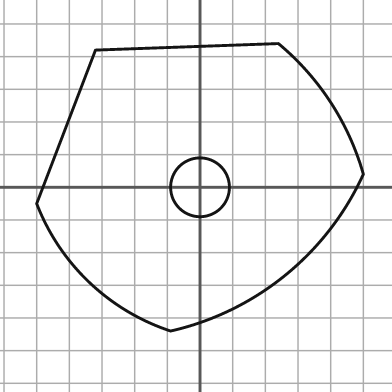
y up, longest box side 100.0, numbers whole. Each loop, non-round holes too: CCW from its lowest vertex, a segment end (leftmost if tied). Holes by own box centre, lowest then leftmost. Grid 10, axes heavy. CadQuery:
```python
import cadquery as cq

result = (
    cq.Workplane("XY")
    .moveTo(-9.0, -44.0)
    .threePointArc((26.0, -27.0), (50.0, 4.0))
    .threePointArc((40.0, 26.0), (24.0, 44.0))
    .lineTo(-32.0, 42.0)
    .lineTo(-50.0, -5.0)
    .threePointArc((-34.0, -29.0), (-9.0, -44.0))
    .close()
    .moveTo(0.0, 0.0)
    .circle(9.0)
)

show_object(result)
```